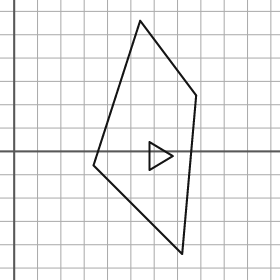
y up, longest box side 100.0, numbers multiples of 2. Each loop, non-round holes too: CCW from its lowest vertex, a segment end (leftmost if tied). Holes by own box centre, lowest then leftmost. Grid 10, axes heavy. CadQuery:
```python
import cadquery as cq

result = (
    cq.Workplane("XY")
    .moveTo(72.0, -44.0)
    .lineTo(78.0, 24.0)
    .lineTo(54.0, 56.0)
    .lineTo(34.0, -6.0)
    .close()
    .moveTo(58.0, -8.0)
    .lineTo(68.0, -2.0)
    .lineTo(58.0, 4.0)
    .close()
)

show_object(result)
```